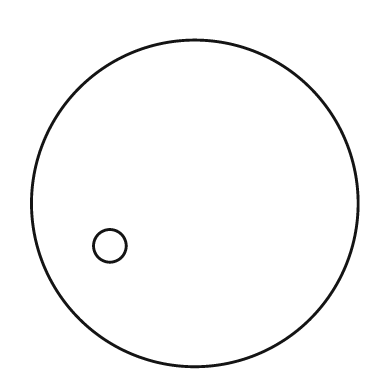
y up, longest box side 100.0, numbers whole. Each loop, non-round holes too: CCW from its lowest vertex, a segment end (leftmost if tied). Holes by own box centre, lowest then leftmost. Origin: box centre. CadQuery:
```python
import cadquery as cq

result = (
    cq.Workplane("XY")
    .moveTo(0.0, 0.0)
    .circle(50.0)
    .moveTo(-26.0, -13.0)
    .circle(5.0)
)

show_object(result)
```